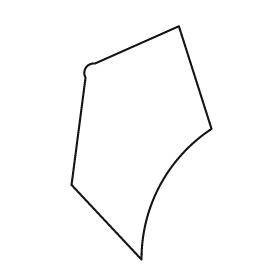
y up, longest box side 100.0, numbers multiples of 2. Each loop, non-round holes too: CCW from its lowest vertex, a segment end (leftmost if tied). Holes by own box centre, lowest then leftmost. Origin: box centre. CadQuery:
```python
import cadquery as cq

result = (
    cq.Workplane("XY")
    .moveTo(0.0, -50.0)
    .threePointArc((8.0, -18.0), (30.0, 6.0))
    .lineTo(16.0, 50.0)
    .lineTo(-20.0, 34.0)
    .threePointArc((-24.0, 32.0), (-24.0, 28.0))
    .lineTo(-30.0, -18.0)
    .close()
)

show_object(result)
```